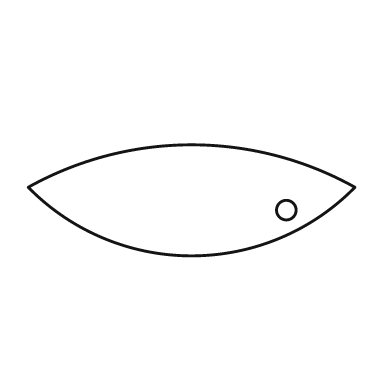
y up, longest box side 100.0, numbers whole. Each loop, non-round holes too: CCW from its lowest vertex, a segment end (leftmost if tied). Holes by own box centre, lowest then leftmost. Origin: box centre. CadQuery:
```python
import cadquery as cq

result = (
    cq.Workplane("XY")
    .moveTo(-50.0, 4.0)
    .threePointArc((0.0, -17.0), (50.0, 4.0))
    .threePointArc((0.0, 17.0), (-50.0, 4.0))
    .close()
    .moveTo(29.0, -3.0)
    .circle(3.0)
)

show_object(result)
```